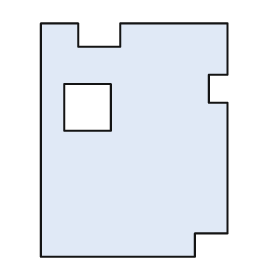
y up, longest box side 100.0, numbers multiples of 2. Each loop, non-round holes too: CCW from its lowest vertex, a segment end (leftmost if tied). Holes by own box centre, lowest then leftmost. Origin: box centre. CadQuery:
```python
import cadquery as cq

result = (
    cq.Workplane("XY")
    .moveTo(-40.0, -50.0)
    .lineTo(26.0, -50.0)
    .lineTo(26.0, -40.0)
    .lineTo(40.0, -40.0)
    .lineTo(40.0, 16.0)
    .lineTo(32.0, 16.0)
    .lineTo(32.0, 28.0)
    .lineTo(40.0, 28.0)
    .lineTo(40.0, 50.0)
    .lineTo(-6.0, 50.0)
    .lineTo(-6.0, 40.0)
    .lineTo(-24.0, 40.0)
    .lineTo(-24.0, 50.0)
    .lineTo(-40.0, 50.0)
    .close()
    .moveTo(-30.0, 4.0)
    .lineTo(-10.0, 4.0)
    .lineTo(-10.0, 24.0)
    .lineTo(-30.0, 24.0)
    .close()
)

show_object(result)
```